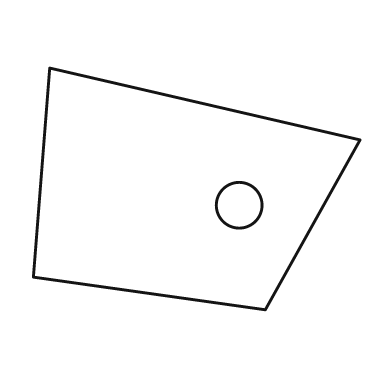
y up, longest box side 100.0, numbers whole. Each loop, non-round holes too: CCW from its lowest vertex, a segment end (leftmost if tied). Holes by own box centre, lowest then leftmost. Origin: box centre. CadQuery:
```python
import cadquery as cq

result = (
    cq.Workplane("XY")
    .moveTo(21.0, -37.0)
    .lineTo(50.0, 15.0)
    .lineTo(-45.0, 37.0)
    .lineTo(-50.0, -27.0)
    .close()
    .moveTo(13.0, -5.0)
    .circle(7.0)
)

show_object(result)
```